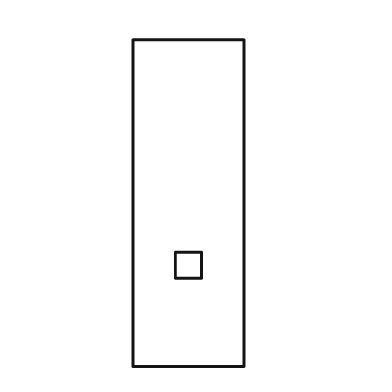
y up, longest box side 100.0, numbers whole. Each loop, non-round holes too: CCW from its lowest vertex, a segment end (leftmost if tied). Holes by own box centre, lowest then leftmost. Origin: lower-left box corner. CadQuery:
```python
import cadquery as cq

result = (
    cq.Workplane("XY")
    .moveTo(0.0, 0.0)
    .lineTo(34.0, 0.0)
    .lineTo(34.0, 100.0)
    .lineTo(0.0, 100.0)
    .close()
    .moveTo(13.0, 27.0)
    .lineTo(21.0, 27.0)
    .lineTo(21.0, 35.0)
    .lineTo(13.0, 35.0)
    .close()
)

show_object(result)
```